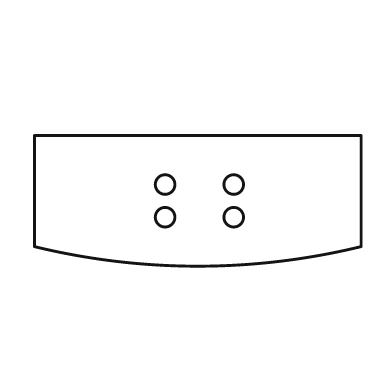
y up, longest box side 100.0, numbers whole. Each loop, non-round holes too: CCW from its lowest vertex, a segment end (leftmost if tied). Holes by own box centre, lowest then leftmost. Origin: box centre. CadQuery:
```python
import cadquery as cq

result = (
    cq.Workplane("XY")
    .moveTo(-50.0, -14.0)
    .threePointArc((0.0, -20.0), (50.0, -14.0))
    .lineTo(50.0, 20.0)
    .lineTo(-50.0, 20.0)
    .close()
    .moveTo(-10.0, -5.0)
    .circle(3.0)
    .moveTo(11.0, -5.0)
    .circle(3.0)
    .moveTo(-10.0, 5.0)
    .circle(3.0)
    .moveTo(11.0, 5.0)
    .circle(3.0)
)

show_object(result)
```